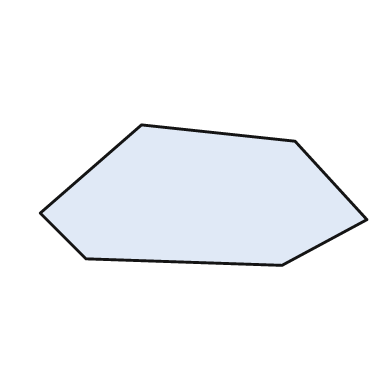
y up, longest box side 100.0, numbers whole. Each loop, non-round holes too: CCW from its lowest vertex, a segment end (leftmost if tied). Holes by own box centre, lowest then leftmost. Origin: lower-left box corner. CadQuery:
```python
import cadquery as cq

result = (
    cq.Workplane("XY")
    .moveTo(74.0, 0.0)
    .lineTo(100.0, 14.0)
    .lineTo(78.0, 38.0)
    .lineTo(31.0, 43.0)
    .lineTo(0.0, 16.0)
    .lineTo(14.0, 2.0)
    .close()
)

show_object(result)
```